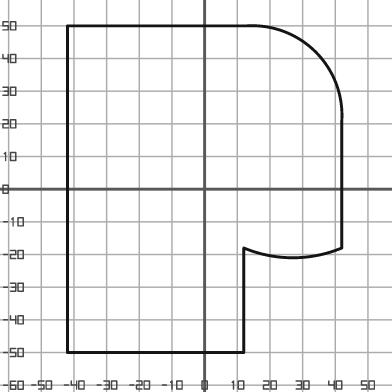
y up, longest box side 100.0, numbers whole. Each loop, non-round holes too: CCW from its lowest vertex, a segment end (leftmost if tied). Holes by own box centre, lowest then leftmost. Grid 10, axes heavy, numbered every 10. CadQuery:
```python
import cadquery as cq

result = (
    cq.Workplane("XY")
    .moveTo(-42.0, -50.0)
    .lineTo(12.0, -50.0)
    .lineTo(12.0, -18.0)
    .threePointArc((27.0, -21.0), (42.0, -18.0))
    .lineTo(42.0, 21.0)
    .threePointArc((34.0, 42.0), (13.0, 50.0))
    .lineTo(-42.0, 50.0)
    .close()
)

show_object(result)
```